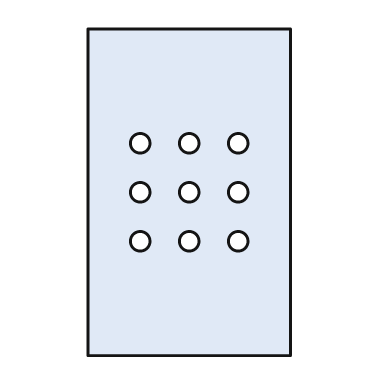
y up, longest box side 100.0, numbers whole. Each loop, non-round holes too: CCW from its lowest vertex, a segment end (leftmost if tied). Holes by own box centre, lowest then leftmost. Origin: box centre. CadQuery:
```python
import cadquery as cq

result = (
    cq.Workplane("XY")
    .moveTo(-31.0, -50.0)
    .lineTo(31.0, -50.0)
    .lineTo(31.0, 50.0)
    .lineTo(-31.0, 50.0)
    .close()
    .moveTo(-15.0, -15.0)
    .circle(3.0)
    .moveTo(0.0, -15.0)
    .circle(3.0)
    .moveTo(15.0, -15.0)
    .circle(3.0)
    .moveTo(-15.0, 0.0)
    .circle(3.0)
    .moveTo(0.0, 0.0)
    .circle(3.0)
    .moveTo(15.0, 0.0)
    .circle(3.0)
    .moveTo(-15.0, 15.0)
    .circle(3.0)
    .moveTo(0.0, 15.0)
    .circle(3.0)
    .moveTo(15.0, 15.0)
    .circle(3.0)
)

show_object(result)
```